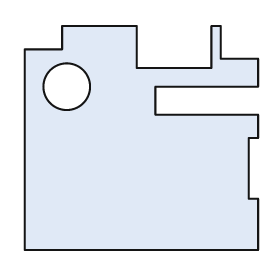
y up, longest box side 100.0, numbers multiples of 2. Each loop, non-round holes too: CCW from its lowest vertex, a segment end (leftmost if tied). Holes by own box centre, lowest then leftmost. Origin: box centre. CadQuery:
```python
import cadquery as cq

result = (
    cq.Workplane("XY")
    .moveTo(-50.0, -48.0)
    .lineTo(50.0, -48.0)
    .lineTo(50.0, -26.0)
    .lineTo(46.0, -26.0)
    .lineTo(46.0, 0.0)
    .lineTo(50.0, 0.0)
    .lineTo(50.0, 10.0)
    .lineTo(6.0, 10.0)
    .lineTo(6.0, 22.0)
    .lineTo(50.0, 22.0)
    .lineTo(50.0, 34.0)
    .lineTo(34.0, 34.0)
    .lineTo(34.0, 48.0)
    .lineTo(30.0, 48.0)
    .lineTo(30.0, 30.0)
    .lineTo(-2.0, 30.0)
    .lineTo(-2.0, 48.0)
    .lineTo(-34.0, 48.0)
    .lineTo(-34.0, 38.0)
    .lineTo(-50.0, 38.0)
    .close()
    .moveTo(-32.0, 22.0)
    .circle(10.0)
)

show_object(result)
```